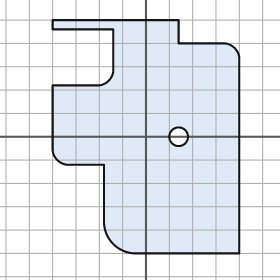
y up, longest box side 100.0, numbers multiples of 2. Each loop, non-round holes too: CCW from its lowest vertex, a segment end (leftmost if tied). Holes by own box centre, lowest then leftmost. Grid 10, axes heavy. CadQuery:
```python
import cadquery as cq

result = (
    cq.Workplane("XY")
    .moveTo(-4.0, -50.0)
    .lineTo(40.0, -50.0)
    .lineTo(40.0, 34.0)
    .threePointArc((38.0, 38.0), (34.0, 40.0))
    .lineTo(14.0, 40.0)
    .lineTo(14.0, 50.0)
    .lineTo(-40.0, 50.0)
    .lineTo(-40.0, 46.0)
    .lineTo(-14.0, 46.0)
    .lineTo(-14.0, 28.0)
    .threePointArc((-16.0, 24.0), (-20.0, 22.0))
    .lineTo(-40.0, 22.0)
    .lineTo(-40.0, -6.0)
    .threePointArc((-38.0, -10.0), (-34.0, -12.0))
    .lineTo(-18.0, -12.0)
    .lineTo(-18.0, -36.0)
    .threePointArc((-14.0, -46.0), (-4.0, -50.0))
    .close()
    .moveTo(14.0, 0.0)
    .circle(4.0)
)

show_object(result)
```